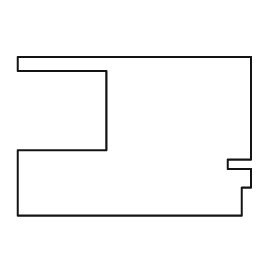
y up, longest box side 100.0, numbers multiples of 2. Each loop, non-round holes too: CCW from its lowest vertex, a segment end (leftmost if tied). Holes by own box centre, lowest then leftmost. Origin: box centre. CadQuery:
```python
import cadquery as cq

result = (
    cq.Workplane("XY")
    .moveTo(-50.0, -34.0)
    .lineTo(46.0, -34.0)
    .lineTo(46.0, -22.0)
    .lineTo(50.0, -22.0)
    .lineTo(50.0, -14.0)
    .lineTo(40.0, -14.0)
    .lineTo(40.0, -10.0)
    .lineTo(50.0, -10.0)
    .lineTo(50.0, 34.0)
    .lineTo(-50.0, 34.0)
    .lineTo(-50.0, 28.0)
    .lineTo(-12.0, 28.0)
    .lineTo(-12.0, -6.0)
    .lineTo(-50.0, -6.0)
    .close()
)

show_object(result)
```